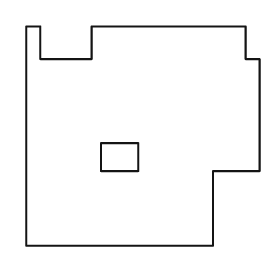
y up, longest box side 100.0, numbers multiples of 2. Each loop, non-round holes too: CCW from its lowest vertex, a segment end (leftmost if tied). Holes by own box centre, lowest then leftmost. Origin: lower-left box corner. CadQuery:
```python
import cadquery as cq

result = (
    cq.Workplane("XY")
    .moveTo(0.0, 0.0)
    .lineTo(80.0, 0.0)
    .lineTo(80.0, 32.0)
    .lineTo(100.0, 32.0)
    .lineTo(100.0, 80.0)
    .lineTo(94.0, 80.0)
    .lineTo(94.0, 94.0)
    .lineTo(28.0, 94.0)
    .lineTo(28.0, 80.0)
    .lineTo(6.0, 80.0)
    .lineTo(6.0, 94.0)
    .lineTo(0.0, 94.0)
    .close()
    .moveTo(32.0, 32.0)
    .lineTo(48.0, 32.0)
    .lineTo(48.0, 44.0)
    .lineTo(32.0, 44.0)
    .close()
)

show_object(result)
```